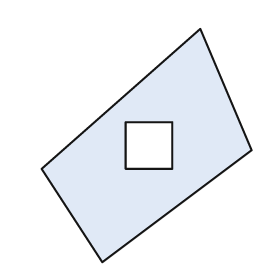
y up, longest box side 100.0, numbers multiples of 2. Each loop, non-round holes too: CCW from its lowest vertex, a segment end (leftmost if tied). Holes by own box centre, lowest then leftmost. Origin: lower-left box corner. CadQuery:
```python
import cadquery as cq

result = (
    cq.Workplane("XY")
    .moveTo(26.0, 0.0)
    .lineTo(90.0, 48.0)
    .lineTo(68.0, 100.0)
    .lineTo(0.0, 40.0)
    .close()
    .moveTo(36.0, 40.0)
    .lineTo(56.0, 40.0)
    .lineTo(56.0, 60.0)
    .lineTo(36.0, 60.0)
    .close()
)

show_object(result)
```